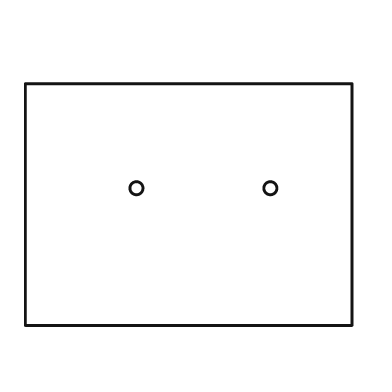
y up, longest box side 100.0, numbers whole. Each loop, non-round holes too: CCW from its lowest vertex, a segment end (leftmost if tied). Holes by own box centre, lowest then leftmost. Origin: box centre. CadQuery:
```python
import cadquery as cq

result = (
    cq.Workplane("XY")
    .moveTo(-50.0, -37.0)
    .lineTo(50.0, -37.0)
    .lineTo(50.0, 37.0)
    .lineTo(-50.0, 37.0)
    .close()
    .moveTo(-16.0, 5.0)
    .circle(2.0)
    .moveTo(25.0, 5.0)
    .circle(2.0)
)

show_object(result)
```